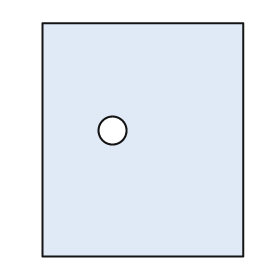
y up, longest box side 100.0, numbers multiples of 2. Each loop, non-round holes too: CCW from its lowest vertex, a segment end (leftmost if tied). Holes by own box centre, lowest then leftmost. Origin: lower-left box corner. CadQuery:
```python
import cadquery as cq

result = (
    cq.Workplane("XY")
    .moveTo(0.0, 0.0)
    .lineTo(86.0, 0.0)
    .lineTo(86.0, 100.0)
    .lineTo(0.0, 100.0)
    .close()
    .moveTo(30.0, 54.0)
    .circle(6.0)
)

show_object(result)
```